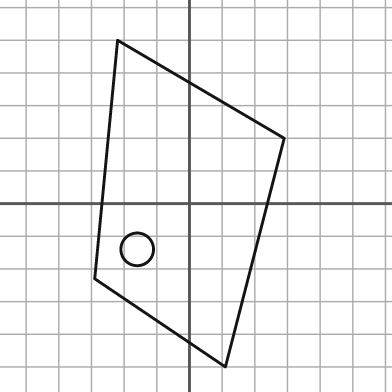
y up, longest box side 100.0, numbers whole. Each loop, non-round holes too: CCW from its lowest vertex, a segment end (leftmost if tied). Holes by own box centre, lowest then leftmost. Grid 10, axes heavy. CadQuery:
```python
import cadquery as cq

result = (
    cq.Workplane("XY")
    .moveTo(11.0, -50.0)
    .lineTo(29.0, 20.0)
    .lineTo(-22.0, 50.0)
    .lineTo(-29.0, -23.0)
    .close()
    .moveTo(-16.0, -14.0)
    .circle(5.0)
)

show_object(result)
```